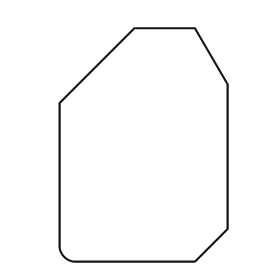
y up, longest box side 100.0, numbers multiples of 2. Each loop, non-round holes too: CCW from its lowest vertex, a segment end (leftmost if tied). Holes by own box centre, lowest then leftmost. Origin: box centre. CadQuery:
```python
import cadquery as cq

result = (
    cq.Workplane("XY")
    .moveTo(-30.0, -50.0)
    .lineTo(22.0, -50.0)
    .lineTo(36.0, -36.0)
    .lineTo(36.0, 26.0)
    .lineTo(22.0, 50.0)
    .lineTo(-4.0, 50.0)
    .lineTo(-36.0, 18.0)
    .lineTo(-36.0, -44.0)
    .threePointArc((-34.0, -48.0), (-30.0, -50.0))
    .close()
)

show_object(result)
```